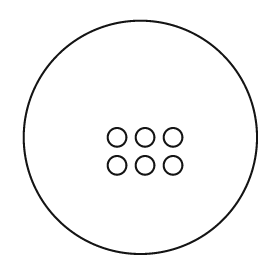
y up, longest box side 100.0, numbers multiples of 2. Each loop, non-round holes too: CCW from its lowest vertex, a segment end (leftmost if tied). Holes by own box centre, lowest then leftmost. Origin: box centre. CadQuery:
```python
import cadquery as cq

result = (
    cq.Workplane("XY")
    .moveTo(0.0, 0.0)
    .circle(50.0)
    .moveTo(-10.0, -12.0)
    .circle(4.0)
    .moveTo(2.0, -12.0)
    .circle(4.0)
    .moveTo(14.0, -12.0)
    .circle(4.0)
    .moveTo(-10.0, 0.0)
    .circle(4.0)
    .moveTo(2.0, 0.0)
    .circle(4.0)
    .moveTo(14.0, 0.0)
    .circle(4.0)
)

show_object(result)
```